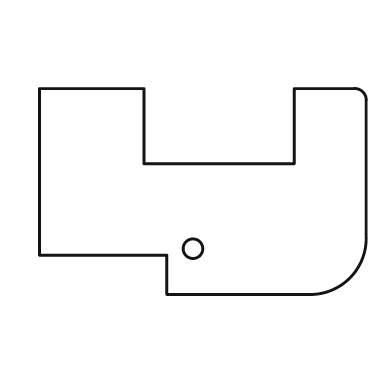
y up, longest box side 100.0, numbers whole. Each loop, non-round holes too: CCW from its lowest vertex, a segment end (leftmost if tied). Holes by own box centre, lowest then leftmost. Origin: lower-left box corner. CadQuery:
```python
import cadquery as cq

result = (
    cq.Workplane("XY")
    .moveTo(39.0, 0.0)
    .lineTo(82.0, 0.0)
    .threePointArc((95.0, 5.0), (100.0, 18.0))
    .lineTo(100.0, 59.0)
    .threePointArc((99.0, 62.0), (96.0, 63.0))
    .lineTo(78.0, 63.0)
    .lineTo(78.0, 40.0)
    .lineTo(32.0, 40.0)
    .lineTo(32.0, 63.0)
    .lineTo(0.0, 63.0)
    .lineTo(0.0, 12.0)
    .lineTo(39.0, 12.0)
    .close()
    .moveTo(47.0, 14.0)
    .circle(3.0)
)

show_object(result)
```